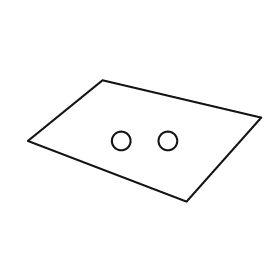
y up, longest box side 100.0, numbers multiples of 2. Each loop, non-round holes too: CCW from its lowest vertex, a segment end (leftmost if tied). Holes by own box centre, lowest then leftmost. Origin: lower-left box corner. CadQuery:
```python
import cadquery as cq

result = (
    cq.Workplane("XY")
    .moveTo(68.0, 0.0)
    .lineTo(100.0, 36.0)
    .lineTo(32.0, 52.0)
    .lineTo(0.0, 26.0)
    .close()
    .moveTo(40.0, 26.0)
    .circle(4.0)
    .moveTo(60.0, 26.0)
    .circle(4.0)
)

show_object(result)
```